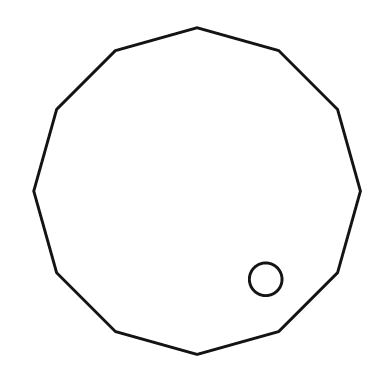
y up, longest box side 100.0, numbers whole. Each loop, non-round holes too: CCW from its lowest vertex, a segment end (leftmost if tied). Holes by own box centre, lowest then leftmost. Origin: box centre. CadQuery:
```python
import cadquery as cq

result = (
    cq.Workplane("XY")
    .moveTo(0.0, -50.0)
    .lineTo(25.0, -43.0)
    .lineTo(43.0, -25.0)
    .lineTo(50.0, 0.0)
    .lineTo(43.0, 25.0)
    .lineTo(25.0, 43.0)
    .lineTo(0.0, 50.0)
    .lineTo(-25.0, 43.0)
    .lineTo(-43.0, 25.0)
    .lineTo(-50.0, 0.0)
    .lineTo(-43.0, -25.0)
    .lineTo(-25.0, -43.0)
    .close()
    .moveTo(21.0, -27.0)
    .circle(5.0)
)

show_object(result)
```